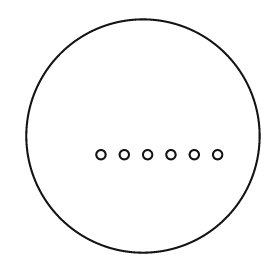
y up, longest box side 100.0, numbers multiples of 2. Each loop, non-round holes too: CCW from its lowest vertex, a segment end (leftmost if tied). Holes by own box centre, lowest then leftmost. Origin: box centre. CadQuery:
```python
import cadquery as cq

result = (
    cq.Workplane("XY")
    .moveTo(0.0, 0.0)
    .circle(50.0)
    .moveTo(-18.0, -8.0)
    .circle(2.0)
    .moveTo(-8.0, -8.0)
    .circle(2.0)
    .moveTo(2.0, -8.0)
    .circle(2.0)
    .moveTo(12.0, -8.0)
    .circle(2.0)
    .moveTo(22.0, -8.0)
    .circle(2.0)
    .moveTo(32.0, -8.0)
    .circle(2.0)
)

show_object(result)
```